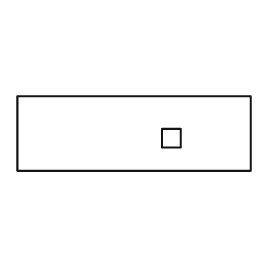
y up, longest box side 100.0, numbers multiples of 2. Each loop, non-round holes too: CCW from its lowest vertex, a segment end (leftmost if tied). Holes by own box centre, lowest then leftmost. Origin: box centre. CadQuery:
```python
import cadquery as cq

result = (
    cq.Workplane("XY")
    .moveTo(-50.0, -16.0)
    .lineTo(50.0, -16.0)
    .lineTo(50.0, 16.0)
    .lineTo(-50.0, 16.0)
    .close()
    .moveTo(12.0, -6.0)
    .lineTo(20.0, -6.0)
    .lineTo(20.0, 2.0)
    .lineTo(12.0, 2.0)
    .close()
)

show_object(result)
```